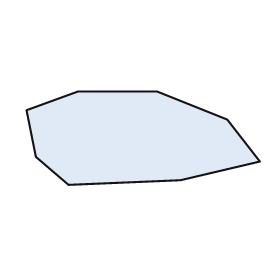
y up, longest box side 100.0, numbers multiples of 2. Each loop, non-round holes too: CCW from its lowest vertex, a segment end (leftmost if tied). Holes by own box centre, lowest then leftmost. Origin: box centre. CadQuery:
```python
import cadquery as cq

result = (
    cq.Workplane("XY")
    .moveTo(-32.0, -20.0)
    .lineTo(16.0, -18.0)
    .lineTo(50.0, -10.0)
    .lineTo(36.0, 8.0)
    .lineTo(6.0, 20.0)
    .lineTo(-28.0, 20.0)
    .lineTo(-50.0, 12.0)
    .lineTo(-46.0, -8.0)
    .close()
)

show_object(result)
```